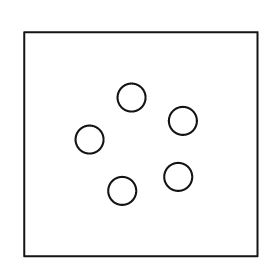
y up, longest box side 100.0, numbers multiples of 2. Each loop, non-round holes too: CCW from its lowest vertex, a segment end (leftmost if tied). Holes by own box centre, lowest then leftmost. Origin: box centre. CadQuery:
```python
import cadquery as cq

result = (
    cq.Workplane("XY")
    .moveTo(-50.0, -48.0)
    .lineTo(50.0, -48.0)
    .lineTo(50.0, 48.0)
    .lineTo(-50.0, 48.0)
    .close()
    .moveTo(-8.0, -20.0)
    .circle(6.0)
    .moveTo(16.0, -14.0)
    .circle(6.0)
    .moveTo(-22.0, 2.0)
    .circle(6.0)
    .moveTo(18.0, 10.0)
    .circle(6.0)
    .moveTo(-4.0, 20.0)
    .circle(6.0)
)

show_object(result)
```